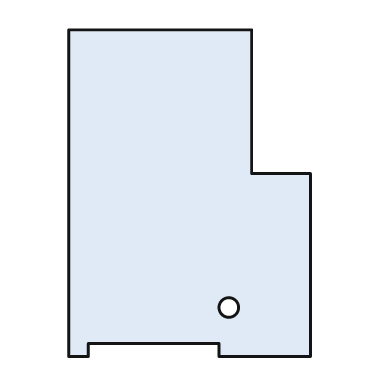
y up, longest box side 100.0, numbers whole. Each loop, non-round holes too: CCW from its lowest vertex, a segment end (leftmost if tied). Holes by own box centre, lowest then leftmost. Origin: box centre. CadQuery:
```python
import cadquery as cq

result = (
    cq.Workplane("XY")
    .moveTo(-37.0, -50.0)
    .lineTo(-31.0, -50.0)
    .lineTo(-31.0, -46.0)
    .lineTo(9.0, -46.0)
    .lineTo(9.0, -50.0)
    .lineTo(37.0, -50.0)
    .lineTo(37.0, 6.0)
    .lineTo(19.0, 6.0)
    .lineTo(19.0, 50.0)
    .lineTo(-37.0, 50.0)
    .close()
    .moveTo(12.0, -35.0)
    .circle(3.0)
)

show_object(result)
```